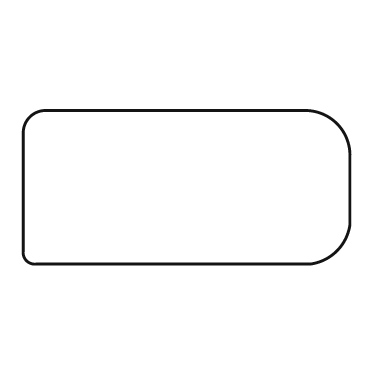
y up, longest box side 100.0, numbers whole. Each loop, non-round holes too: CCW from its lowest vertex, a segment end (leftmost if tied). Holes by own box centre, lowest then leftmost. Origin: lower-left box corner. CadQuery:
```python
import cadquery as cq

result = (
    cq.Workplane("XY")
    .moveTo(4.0, 0.0)
    .lineTo(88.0, 0.0)
    .threePointArc((96.0, 4.0), (100.0, 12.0))
    .lineTo(100.0, 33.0)
    .threePointArc((96.0, 43.0), (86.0, 47.0))
    .lineTo(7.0, 47.0)
    .threePointArc((2.0, 45.0), (0.0, 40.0))
    .lineTo(0.0, 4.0)
    .threePointArc((1.0, 1.0), (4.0, 0.0))
    .close()
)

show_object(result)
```